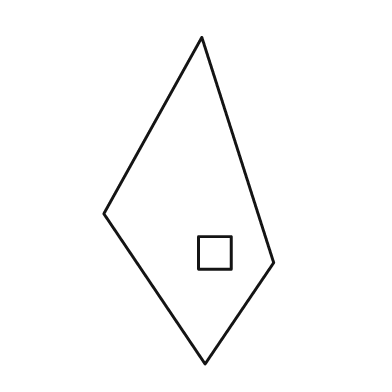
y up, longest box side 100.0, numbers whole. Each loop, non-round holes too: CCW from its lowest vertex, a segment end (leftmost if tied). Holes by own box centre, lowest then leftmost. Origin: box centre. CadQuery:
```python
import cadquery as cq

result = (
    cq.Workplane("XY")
    .moveTo(5.0, -50.0)
    .lineTo(26.0, -19.0)
    .lineTo(4.0, 50.0)
    .lineTo(-26.0, -4.0)
    .close()
    .moveTo(3.0, -21.0)
    .lineTo(13.0, -21.0)
    .lineTo(13.0, -11.0)
    .lineTo(3.0, -11.0)
    .close()
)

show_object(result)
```